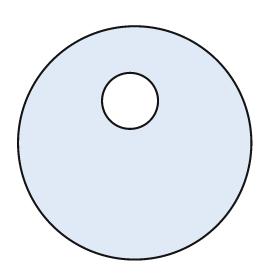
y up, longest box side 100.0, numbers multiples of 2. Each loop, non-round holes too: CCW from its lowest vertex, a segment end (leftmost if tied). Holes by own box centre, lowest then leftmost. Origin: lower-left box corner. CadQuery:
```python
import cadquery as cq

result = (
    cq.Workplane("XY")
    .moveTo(50.0, 50.0)
    .circle(50.0)
    .moveTo(48.0, 68.0)
    .circle(12.0)
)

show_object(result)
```